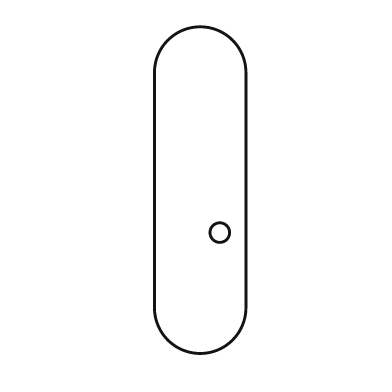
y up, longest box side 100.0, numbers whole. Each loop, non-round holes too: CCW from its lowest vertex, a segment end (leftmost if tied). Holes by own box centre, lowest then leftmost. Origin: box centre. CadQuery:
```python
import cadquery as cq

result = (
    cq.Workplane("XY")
    .moveTo(-14.0, -36.0)
    .threePointArc((0.0, -50.0), (14.0, -36.0))
    .lineTo(14.0, 36.0)
    .threePointArc((0.0, 50.0), (-14.0, 36.0))
    .close()
    .moveTo(6.0, -13.0)
    .circle(3.0)
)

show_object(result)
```